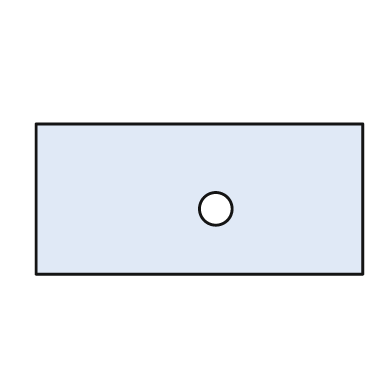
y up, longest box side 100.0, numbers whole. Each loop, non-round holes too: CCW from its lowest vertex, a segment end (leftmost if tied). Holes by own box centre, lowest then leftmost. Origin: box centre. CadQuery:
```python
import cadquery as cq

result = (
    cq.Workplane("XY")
    .moveTo(-50.0, -23.0)
    .lineTo(50.0, -23.0)
    .lineTo(50.0, 23.0)
    .lineTo(-50.0, 23.0)
    .close()
    .moveTo(5.0, -3.0)
    .circle(5.0)
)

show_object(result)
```